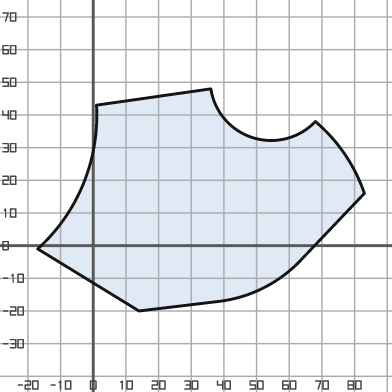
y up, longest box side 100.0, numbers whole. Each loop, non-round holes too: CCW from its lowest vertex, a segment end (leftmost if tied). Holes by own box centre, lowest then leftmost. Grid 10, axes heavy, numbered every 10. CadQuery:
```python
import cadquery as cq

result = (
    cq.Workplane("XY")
    .moveTo(14.0, -20.0)
    .lineTo(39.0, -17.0)
    .threePointArc((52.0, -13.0), (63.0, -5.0))
    .lineTo(83.0, 16.0)
    .threePointArc((77.0, 28.0), (68.0, 38.0))
    .threePointArc((49.0, 33.0), (36.0, 48.0))
    .lineTo(1.0, 43.0)
    .threePointArc((-3.0, 19.0), (-17.0, -1.0))
    .close()
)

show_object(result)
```